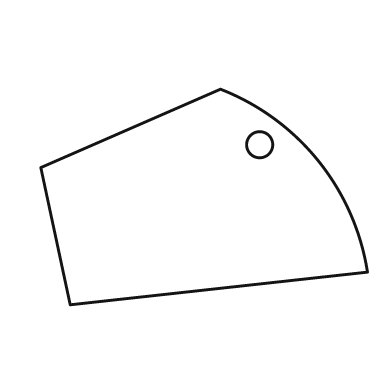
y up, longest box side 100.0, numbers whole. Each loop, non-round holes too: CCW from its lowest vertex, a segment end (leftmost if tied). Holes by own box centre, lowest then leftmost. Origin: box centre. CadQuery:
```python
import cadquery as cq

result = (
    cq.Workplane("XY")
    .moveTo(-41.0, -33.0)
    .lineTo(50.0, -23.0)
    .threePointArc((35.0, 11.0), (5.0, 33.0))
    .lineTo(-50.0, 9.0)
    .close()
    .moveTo(17.0, 16.0)
    .circle(4.0)
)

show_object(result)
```